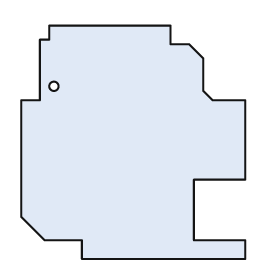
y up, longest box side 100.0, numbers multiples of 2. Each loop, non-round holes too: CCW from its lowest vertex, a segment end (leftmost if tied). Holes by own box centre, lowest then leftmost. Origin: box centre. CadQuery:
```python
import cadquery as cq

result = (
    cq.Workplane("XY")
    .moveTo(-22.0, -50.0)
    .lineTo(48.0, -50.0)
    .lineTo(48.0, -42.0)
    .lineTo(26.0, -42.0)
    .lineTo(26.0, -16.0)
    .lineTo(48.0, -16.0)
    .lineTo(48.0, 18.0)
    .lineTo(34.0, 18.0)
    .lineTo(30.0, 22.0)
    .lineTo(30.0, 36.0)
    .lineTo(24.0, 42.0)
    .lineTo(16.0, 42.0)
    .lineTo(16.0, 50.0)
    .lineTo(-36.0, 50.0)
    .lineTo(-36.0, 44.0)
    .lineTo(-40.0, 44.0)
    .lineTo(-40.0, 18.0)
    .lineTo(-48.0, 18.0)
    .lineTo(-48.0, -32.0)
    .lineTo(-38.0, -42.0)
    .lineTo(-22.0, -42.0)
    .close()
    .moveTo(-34.0, 24.0)
    .circle(2.0)
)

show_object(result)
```